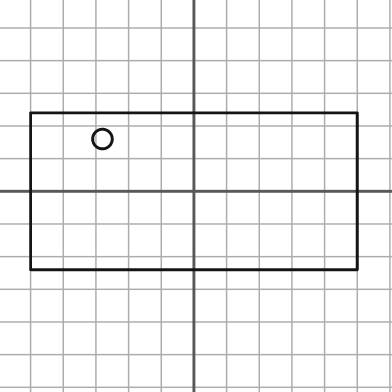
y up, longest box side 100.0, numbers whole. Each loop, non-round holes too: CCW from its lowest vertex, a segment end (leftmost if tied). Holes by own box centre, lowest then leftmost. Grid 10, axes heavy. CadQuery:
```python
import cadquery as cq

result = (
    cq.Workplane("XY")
    .moveTo(-50.0, -24.0)
    .lineTo(50.0, -24.0)
    .lineTo(50.0, 24.0)
    .lineTo(-50.0, 24.0)
    .close()
    .moveTo(-28.0, 16.0)
    .circle(3.0)
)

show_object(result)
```